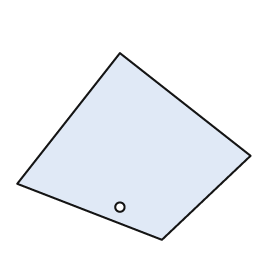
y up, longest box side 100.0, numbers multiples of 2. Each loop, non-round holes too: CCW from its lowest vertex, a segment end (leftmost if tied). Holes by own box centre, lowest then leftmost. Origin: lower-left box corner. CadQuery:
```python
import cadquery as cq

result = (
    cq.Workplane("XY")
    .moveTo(62.0, 0.0)
    .lineTo(100.0, 36.0)
    .lineTo(44.0, 80.0)
    .lineTo(0.0, 24.0)
    .close()
    .moveTo(44.0, 14.0)
    .circle(2.0)
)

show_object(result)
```